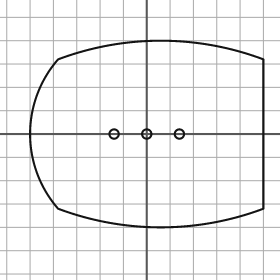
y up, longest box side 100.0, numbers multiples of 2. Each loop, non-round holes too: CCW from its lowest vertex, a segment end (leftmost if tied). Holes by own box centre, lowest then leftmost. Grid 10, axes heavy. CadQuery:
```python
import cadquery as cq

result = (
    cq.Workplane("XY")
    .moveTo(-38.0, -32.0)
    .threePointArc((6.0, -40.0), (50.0, -32.0))
    .lineTo(50.0, 32.0)
    .threePointArc((6.0, 40.0), (-38.0, 32.0))
    .threePointArc((-50.0, 0.0), (-38.0, -32.0))
    .close()
    .moveTo(-14.0, 0.0)
    .circle(2.0)
    .moveTo(0.0, 0.0)
    .circle(2.0)
    .moveTo(14.0, 0.0)
    .circle(2.0)
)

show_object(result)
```